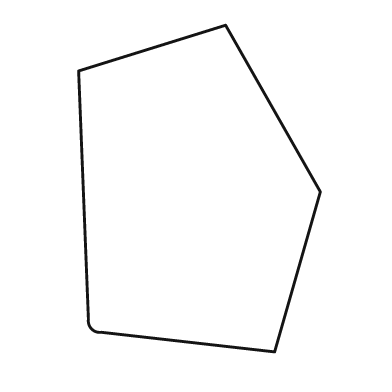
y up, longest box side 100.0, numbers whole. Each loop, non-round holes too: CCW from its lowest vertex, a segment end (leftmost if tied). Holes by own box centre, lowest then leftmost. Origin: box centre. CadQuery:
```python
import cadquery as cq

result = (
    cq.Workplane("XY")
    .moveTo(23.0, -50.0)
    .lineTo(37.0, -1.0)
    .lineTo(8.0, 50.0)
    .lineTo(-37.0, 36.0)
    .lineTo(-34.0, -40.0)
    .threePointArc((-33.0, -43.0), (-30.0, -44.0))
    .close()
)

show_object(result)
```